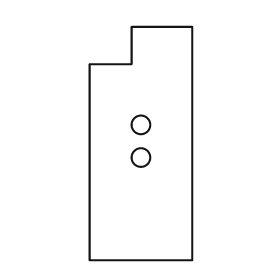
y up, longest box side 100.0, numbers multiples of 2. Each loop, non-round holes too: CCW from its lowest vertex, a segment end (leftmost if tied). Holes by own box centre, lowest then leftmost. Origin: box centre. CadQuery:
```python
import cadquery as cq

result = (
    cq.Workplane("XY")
    .moveTo(-22.0, -50.0)
    .lineTo(22.0, -50.0)
    .lineTo(22.0, 50.0)
    .lineTo(-4.0, 50.0)
    .lineTo(-4.0, 34.0)
    .lineTo(-22.0, 34.0)
    .close()
    .moveTo(0.0, -6.0)
    .circle(4.0)
    .moveTo(0.0, 8.0)
    .circle(4.0)
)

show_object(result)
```